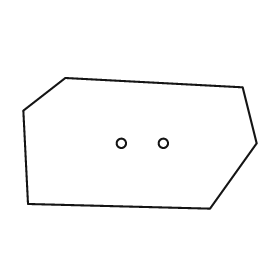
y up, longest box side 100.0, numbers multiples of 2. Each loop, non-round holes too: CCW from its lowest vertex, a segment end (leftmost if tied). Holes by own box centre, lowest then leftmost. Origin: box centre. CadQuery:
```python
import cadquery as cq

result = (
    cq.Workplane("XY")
    .moveTo(30.0, -28.0)
    .lineTo(50.0, 0.0)
    .lineTo(44.0, 24.0)
    .lineTo(-32.0, 28.0)
    .lineTo(-50.0, 14.0)
    .lineTo(-48.0, -26.0)
    .close()
    .moveTo(-8.0, 0.0)
    .circle(2.0)
    .moveTo(10.0, 0.0)
    .circle(2.0)
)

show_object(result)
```